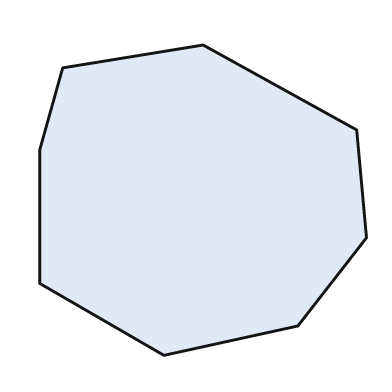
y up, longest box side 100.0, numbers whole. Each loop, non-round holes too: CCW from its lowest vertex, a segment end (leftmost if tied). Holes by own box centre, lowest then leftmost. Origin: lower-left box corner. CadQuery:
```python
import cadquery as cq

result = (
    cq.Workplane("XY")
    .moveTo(38.0, 0.0)
    .lineTo(79.0, 9.0)
    .lineTo(100.0, 36.0)
    .lineTo(97.0, 69.0)
    .lineTo(50.0, 95.0)
    .lineTo(7.0, 88.0)
    .lineTo(0.0, 63.0)
    .lineTo(0.0, 22.0)
    .close()
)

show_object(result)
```